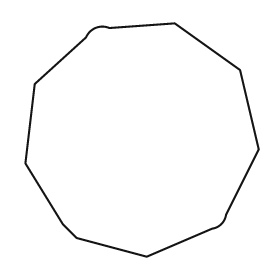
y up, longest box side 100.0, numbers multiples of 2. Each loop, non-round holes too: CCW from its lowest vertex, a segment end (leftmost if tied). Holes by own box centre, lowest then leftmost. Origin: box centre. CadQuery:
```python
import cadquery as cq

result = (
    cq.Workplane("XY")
    .moveTo(2.0, -50.0)
    .lineTo(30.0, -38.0)
    .threePointArc((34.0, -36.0), (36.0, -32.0))
    .lineTo(50.0, -4.0)
    .lineTo(42.0, 30.0)
    .lineTo(14.0, 50.0)
    .lineTo(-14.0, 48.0)
    .threePointArc((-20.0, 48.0), (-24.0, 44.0))
    .lineTo(-46.0, 24.0)
    .lineTo(-50.0, -10.0)
    .lineTo(-34.0, -36.0)
    .lineTo(-28.0, -42.0)
    .close()
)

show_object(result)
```